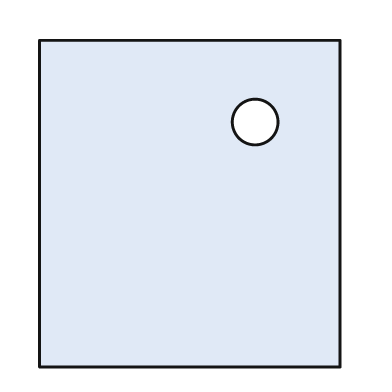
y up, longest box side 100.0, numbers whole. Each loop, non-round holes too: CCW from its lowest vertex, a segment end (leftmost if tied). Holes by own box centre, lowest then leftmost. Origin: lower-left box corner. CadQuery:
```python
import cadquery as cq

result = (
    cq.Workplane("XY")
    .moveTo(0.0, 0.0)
    .lineTo(92.0, 0.0)
    .lineTo(92.0, 100.0)
    .lineTo(0.0, 100.0)
    .close()
    .moveTo(66.0, 75.0)
    .circle(7.0)
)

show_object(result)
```